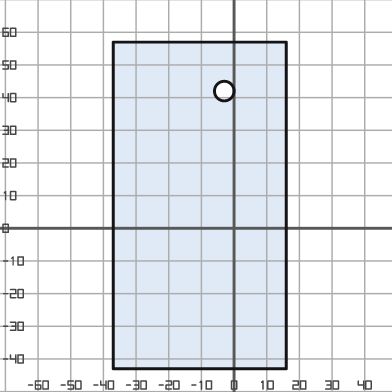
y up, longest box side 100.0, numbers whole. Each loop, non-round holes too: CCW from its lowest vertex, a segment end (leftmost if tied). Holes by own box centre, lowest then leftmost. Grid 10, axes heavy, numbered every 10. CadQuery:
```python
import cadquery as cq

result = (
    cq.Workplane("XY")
    .moveTo(-37.0, -43.0)
    .lineTo(16.0, -43.0)
    .lineTo(16.0, 57.0)
    .lineTo(-37.0, 57.0)
    .close()
    .moveTo(-3.0, 42.0)
    .circle(3.0)
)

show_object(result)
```